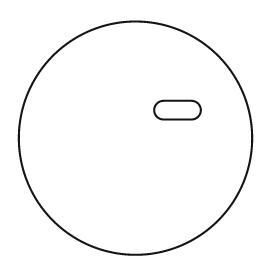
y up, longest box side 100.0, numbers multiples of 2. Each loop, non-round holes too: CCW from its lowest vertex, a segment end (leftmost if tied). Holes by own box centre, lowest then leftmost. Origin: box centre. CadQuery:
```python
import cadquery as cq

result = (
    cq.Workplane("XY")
    .moveTo(0.0, 0.0)
    .circle(50.0)
    .moveTo(12.0, 8.0)
    .lineTo(24.0, 8.0)
    .threePointArc((28.0, 12.0), (24.0, 16.0))
    .lineTo(12.0, 16.0)
    .threePointArc((8.0, 12.0), (12.0, 8.0))
    .close()
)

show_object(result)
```